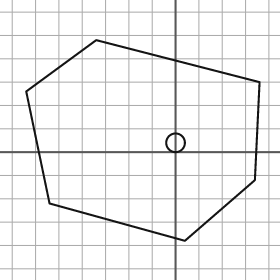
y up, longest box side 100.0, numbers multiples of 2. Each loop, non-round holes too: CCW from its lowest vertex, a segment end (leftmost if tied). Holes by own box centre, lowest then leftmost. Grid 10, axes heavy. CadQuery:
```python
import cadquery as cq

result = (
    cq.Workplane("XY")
    .moveTo(4.0, -38.0)
    .lineTo(34.0, -12.0)
    .lineTo(36.0, 30.0)
    .lineTo(-34.0, 48.0)
    .lineTo(-64.0, 26.0)
    .lineTo(-54.0, -22.0)
    .close()
    .moveTo(0.0, 4.0)
    .circle(4.0)
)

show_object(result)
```